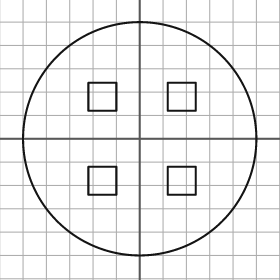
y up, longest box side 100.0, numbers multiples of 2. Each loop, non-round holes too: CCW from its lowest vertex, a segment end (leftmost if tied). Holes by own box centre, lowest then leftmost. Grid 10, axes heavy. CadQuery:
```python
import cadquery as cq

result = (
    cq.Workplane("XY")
    .moveTo(0.0, 0.0)
    .circle(50.0)
    .moveTo(-22.0, -24.0)
    .lineTo(-10.0, -24.0)
    .lineTo(-10.0, -12.0)
    .lineTo(-22.0, -12.0)
    .close()
    .moveTo(12.0, -24.0)
    .lineTo(24.0, -24.0)
    .lineTo(24.0, -12.0)
    .lineTo(12.0, -12.0)
    .close()
    .moveTo(-22.0, 12.0)
    .lineTo(-10.0, 12.0)
    .lineTo(-10.0, 24.0)
    .lineTo(-22.0, 24.0)
    .close()
    .moveTo(12.0, 12.0)
    .lineTo(24.0, 12.0)
    .lineTo(24.0, 24.0)
    .lineTo(12.0, 24.0)
    .close()
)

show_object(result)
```